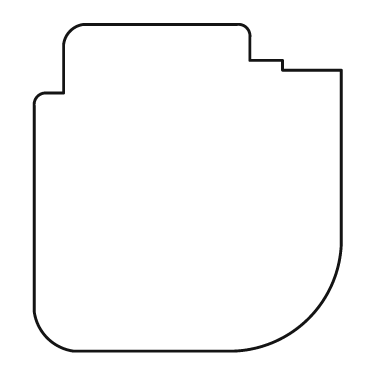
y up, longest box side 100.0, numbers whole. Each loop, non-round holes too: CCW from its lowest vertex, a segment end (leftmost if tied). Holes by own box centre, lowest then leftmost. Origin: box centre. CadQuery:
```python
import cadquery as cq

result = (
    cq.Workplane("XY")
    .moveTo(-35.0, -50.0)
    .lineTo(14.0, -50.0)
    .threePointArc((37.0, -40.0), (47.0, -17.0))
    .lineTo(47.0, 36.0)
    .lineTo(29.0, 36.0)
    .lineTo(29.0, 39.0)
    .lineTo(19.0, 39.0)
    .lineTo(19.0, 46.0)
    .threePointArc((18.0, 49.0), (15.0, 50.0))
    .lineTo(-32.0, 50.0)
    .threePointArc((-36.0, 48.0), (-38.0, 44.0))
    .lineTo(-38.0, 29.0)
    .lineTo(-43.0, 29.0)
    .threePointArc((-46.0, 28.0), (-47.0, 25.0))
    .lineTo(-47.0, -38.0)
    .threePointArc((-43.0, -46.0), (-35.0, -50.0))
    .close()
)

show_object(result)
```